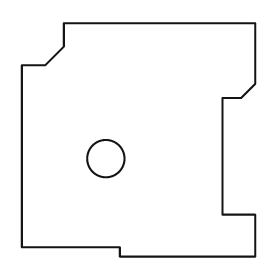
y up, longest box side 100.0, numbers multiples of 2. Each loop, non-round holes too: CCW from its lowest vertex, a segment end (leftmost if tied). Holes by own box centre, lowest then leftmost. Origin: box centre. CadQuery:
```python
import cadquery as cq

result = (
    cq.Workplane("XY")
    .moveTo(-8.0, -50.0)
    .lineTo(50.0, -50.0)
    .lineTo(50.0, -32.0)
    .lineTo(36.0, -32.0)
    .lineTo(36.0, 18.0)
    .lineTo(44.0, 18.0)
    .lineTo(50.0, 24.0)
    .lineTo(50.0, 50.0)
    .lineTo(-32.0, 50.0)
    .lineTo(-32.0, 40.0)
    .lineTo(-40.0, 32.0)
    .lineTo(-50.0, 32.0)
    .lineTo(-50.0, -46.0)
    .lineTo(-8.0, -46.0)
    .close()
    .moveTo(-14.0, -8.0)
    .circle(8.0)
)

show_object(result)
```